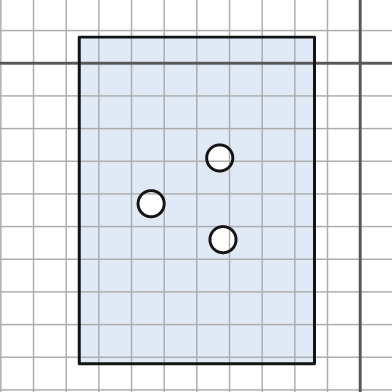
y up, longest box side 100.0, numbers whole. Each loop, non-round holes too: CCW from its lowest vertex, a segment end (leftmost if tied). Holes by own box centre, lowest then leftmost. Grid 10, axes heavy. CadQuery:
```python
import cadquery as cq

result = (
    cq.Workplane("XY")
    .moveTo(-86.0, -92.0)
    .lineTo(-14.0, -92.0)
    .lineTo(-14.0, 8.0)
    .lineTo(-86.0, 8.0)
    .close()
    .moveTo(-42.0, -54.0)
    .circle(4.0)
    .moveTo(-64.0, -43.0)
    .circle(4.0)
    .moveTo(-43.0, -29.0)
    .circle(4.0)
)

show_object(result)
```